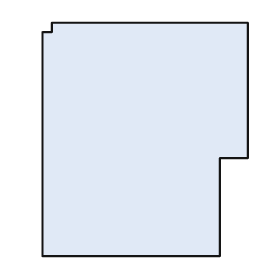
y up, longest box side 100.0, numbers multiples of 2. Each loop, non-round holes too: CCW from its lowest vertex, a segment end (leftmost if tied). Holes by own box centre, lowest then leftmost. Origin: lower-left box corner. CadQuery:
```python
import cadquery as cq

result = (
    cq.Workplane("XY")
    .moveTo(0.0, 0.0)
    .lineTo(76.0, 0.0)
    .lineTo(76.0, 42.0)
    .lineTo(88.0, 42.0)
    .lineTo(88.0, 100.0)
    .lineTo(4.0, 100.0)
    .lineTo(4.0, 96.0)
    .lineTo(0.0, 96.0)
    .close()
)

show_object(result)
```